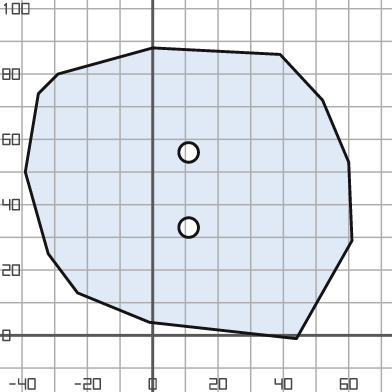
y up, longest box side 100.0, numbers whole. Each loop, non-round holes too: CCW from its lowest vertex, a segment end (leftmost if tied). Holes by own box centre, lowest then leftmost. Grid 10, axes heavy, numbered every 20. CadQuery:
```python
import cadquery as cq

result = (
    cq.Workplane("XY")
    .moveTo(44.0, -1.0)
    .lineTo(61.0, 29.0)
    .lineTo(60.0, 53.0)
    .lineTo(52.0, 72.0)
    .lineTo(39.0, 86.0)
    .lineTo(0.0, 88.0)
    .lineTo(-29.0, 80.0)
    .lineTo(-35.0, 74.0)
    .lineTo(-39.0, 50.0)
    .lineTo(-32.0, 25.0)
    .lineTo(-23.0, 13.0)
    .lineTo(-1.0, 4.0)
    .close()
    .moveTo(11.0, 33.0)
    .circle(3.0)
    .moveTo(11.0, 56.0)
    .circle(3.0)
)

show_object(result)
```